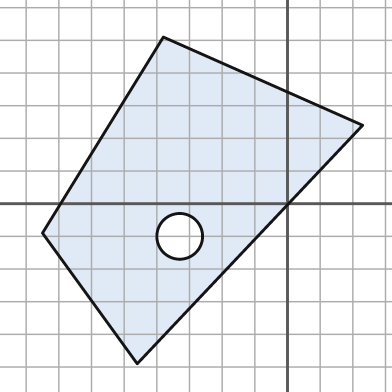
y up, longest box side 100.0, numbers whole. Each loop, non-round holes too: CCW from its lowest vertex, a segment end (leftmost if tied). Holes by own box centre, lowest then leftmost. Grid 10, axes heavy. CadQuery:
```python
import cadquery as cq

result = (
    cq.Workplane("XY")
    .moveTo(-46.0, -49.0)
    .lineTo(23.0, 24.0)
    .lineTo(-38.0, 51.0)
    .lineTo(-75.0, -9.0)
    .close()
    .moveTo(-33.0, -10.0)
    .circle(7.0)
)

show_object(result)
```